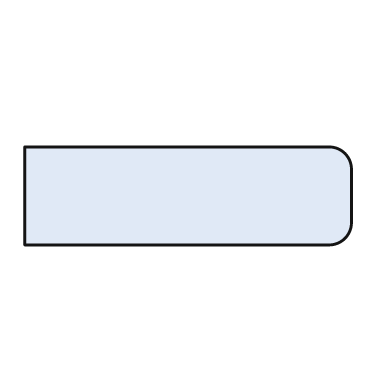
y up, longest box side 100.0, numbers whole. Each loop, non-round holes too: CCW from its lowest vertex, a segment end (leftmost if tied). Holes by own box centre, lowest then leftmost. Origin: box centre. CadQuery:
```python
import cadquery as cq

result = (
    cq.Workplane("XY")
    .moveTo(-50.0, -15.0)
    .lineTo(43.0, -15.0)
    .threePointArc((48.0, -13.0), (50.0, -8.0))
    .lineTo(50.0, 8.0)
    .threePointArc((48.0, 13.0), (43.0, 15.0))
    .lineTo(-50.0, 15.0)
    .close()
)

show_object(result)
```